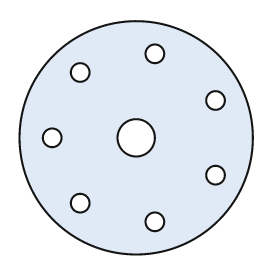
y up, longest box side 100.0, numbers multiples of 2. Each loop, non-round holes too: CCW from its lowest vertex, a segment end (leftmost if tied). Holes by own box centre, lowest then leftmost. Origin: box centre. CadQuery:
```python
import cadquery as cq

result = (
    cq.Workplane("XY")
    .moveTo(0.0, 0.0)
    .circle(50.0)
    .moveTo(8.0, -36.0)
    .circle(4.0)
    .moveTo(-24.0, -28.0)
    .circle(4.0)
    .moveTo(34.0, -16.0)
    .circle(4.0)
    .moveTo(-36.0, 0.0)
    .circle(4.0)
    .moveTo(0.0, 0.0)
    .circle(8.0)
    .moveTo(34.0, 16.0)
    .circle(4.0)
    .moveTo(-24.0, 28.0)
    .circle(4.0)
    .moveTo(8.0, 36.0)
    .circle(4.0)
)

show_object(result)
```